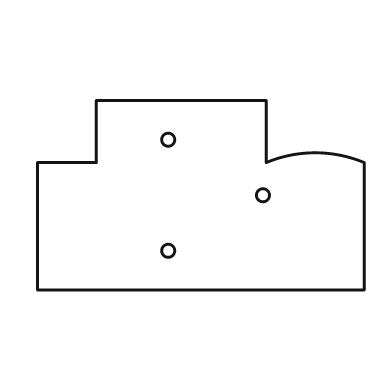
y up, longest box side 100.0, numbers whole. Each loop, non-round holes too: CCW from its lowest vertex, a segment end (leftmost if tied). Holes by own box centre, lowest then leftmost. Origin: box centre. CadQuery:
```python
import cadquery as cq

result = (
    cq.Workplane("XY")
    .moveTo(-50.0, -29.0)
    .lineTo(50.0, -29.0)
    .lineTo(50.0, 10.0)
    .threePointArc((35.0, 13.0), (20.0, 10.0))
    .lineTo(20.0, 29.0)
    .lineTo(-32.0, 29.0)
    .lineTo(-32.0, 10.0)
    .lineTo(-50.0, 10.0)
    .close()
    .moveTo(-10.0, -17.0)
    .circle(2.0)
    .moveTo(19.0, 0.0)
    .circle(2.0)
    .moveTo(-10.0, 17.0)
    .circle(2.0)
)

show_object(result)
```